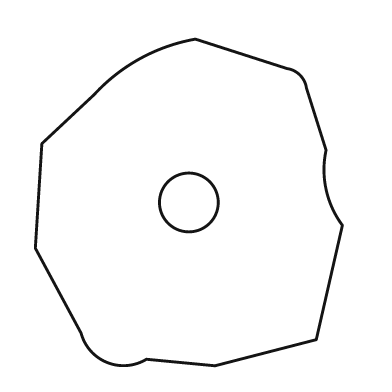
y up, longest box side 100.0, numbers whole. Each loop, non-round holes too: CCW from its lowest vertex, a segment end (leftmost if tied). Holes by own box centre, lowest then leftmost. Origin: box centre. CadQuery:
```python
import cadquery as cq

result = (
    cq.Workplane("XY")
    .moveTo(8.0, -50.0)
    .lineTo(39.0, -42.0)
    .lineTo(47.0, -7.0)
    .threePointArc((42.0, 4.0), (42.0, 16.0))
    .lineTo(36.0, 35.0)
    .threePointArc((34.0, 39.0), (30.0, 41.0))
    .lineTo(2.0, 50.0)
    .threePointArc((-15.0, 44.0), (-29.0, 33.0))
    .lineTo(-45.0, 18.0)
    .lineTo(-47.0, -14.0)
    .lineTo(-33.0, -40.0)
    .threePointArc((-25.0, -49.0), (-13.0, -48.0))
    .close()
    .moveTo(0.0, 0.0)
    .circle(9.0)
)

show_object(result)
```